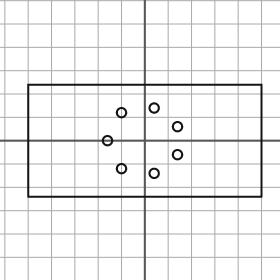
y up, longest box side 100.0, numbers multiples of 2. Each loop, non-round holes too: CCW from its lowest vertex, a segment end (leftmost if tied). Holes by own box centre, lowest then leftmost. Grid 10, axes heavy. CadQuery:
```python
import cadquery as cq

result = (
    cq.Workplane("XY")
    .moveTo(-50.0, -24.0)
    .lineTo(50.0, -24.0)
    .lineTo(50.0, 24.0)
    .lineTo(-50.0, 24.0)
    .close()
    .moveTo(4.0, -14.0)
    .circle(2.0)
    .moveTo(-10.0, -12.0)
    .circle(2.0)
    .moveTo(14.0, -6.0)
    .circle(2.0)
    .moveTo(-16.0, 0.0)
    .circle(2.0)
    .moveTo(14.0, 6.0)
    .circle(2.0)
    .moveTo(-10.0, 12.0)
    .circle(2.0)
    .moveTo(4.0, 14.0)
    .circle(2.0)
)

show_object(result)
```